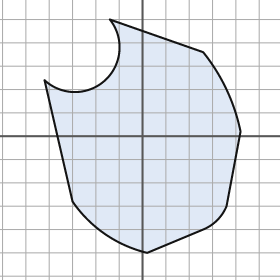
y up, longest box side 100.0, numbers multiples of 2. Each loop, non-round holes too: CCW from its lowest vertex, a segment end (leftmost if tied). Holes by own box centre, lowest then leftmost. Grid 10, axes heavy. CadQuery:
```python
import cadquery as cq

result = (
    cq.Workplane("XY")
    .moveTo(2.0, -50.0)
    .lineTo(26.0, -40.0)
    .threePointArc((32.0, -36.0), (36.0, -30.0))
    .lineTo(42.0, 2.0)
    .threePointArc((36.0, 20.0), (26.0, 36.0))
    .lineTo(-14.0, 50.0)
    .threePointArc((-16.0, 24.0), (-42.0, 24.0))
    .lineTo(-30.0, -28.0)
    .threePointArc((-16.0, -42.0), (2.0, -50.0))
    .close()
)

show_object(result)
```